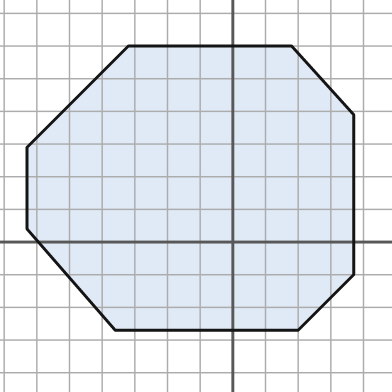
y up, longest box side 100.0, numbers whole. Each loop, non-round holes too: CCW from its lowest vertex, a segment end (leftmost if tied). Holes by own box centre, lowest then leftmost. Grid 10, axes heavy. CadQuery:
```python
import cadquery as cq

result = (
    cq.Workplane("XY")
    .moveTo(-36.0, -27.0)
    .lineTo(20.0, -27.0)
    .lineTo(37.0, -10.0)
    .lineTo(37.0, 39.0)
    .lineTo(18.0, 60.0)
    .lineTo(-32.0, 60.0)
    .lineTo(-63.0, 29.0)
    .lineTo(-63.0, 4.0)
    .close()
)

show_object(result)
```